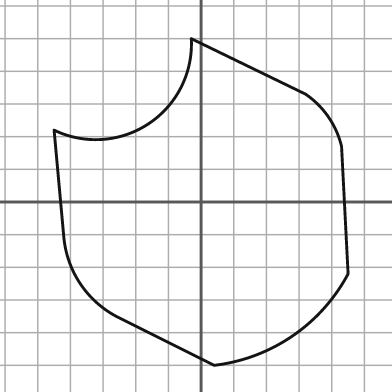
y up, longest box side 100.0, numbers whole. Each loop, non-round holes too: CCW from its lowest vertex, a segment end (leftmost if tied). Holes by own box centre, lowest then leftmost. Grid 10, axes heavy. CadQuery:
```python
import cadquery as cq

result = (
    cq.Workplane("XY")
    .moveTo(4.0, -50.0)
    .threePointArc((28.0, -41.0), (45.0, -22.0))
    .lineTo(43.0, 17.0)
    .threePointArc((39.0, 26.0), (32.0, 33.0))
    .lineTo(-3.0, 50.0)
    .threePointArc((-16.0, 24.0), (-45.0, 22.0))
    .lineTo(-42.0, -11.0)
    .threePointArc((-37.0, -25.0), (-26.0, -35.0))
    .close()
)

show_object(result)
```